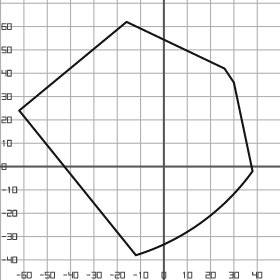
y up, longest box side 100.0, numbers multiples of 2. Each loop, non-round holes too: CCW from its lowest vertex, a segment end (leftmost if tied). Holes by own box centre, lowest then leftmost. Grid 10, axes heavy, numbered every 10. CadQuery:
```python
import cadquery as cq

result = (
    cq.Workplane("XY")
    .moveTo(-12.0, -38.0)
    .threePointArc((16.0, -24.0), (38.0, -2.0))
    .lineTo(30.0, 36.0)
    .lineTo(26.0, 42.0)
    .lineTo(-16.0, 62.0)
    .lineTo(-62.0, 24.0)
    .close()
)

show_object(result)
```